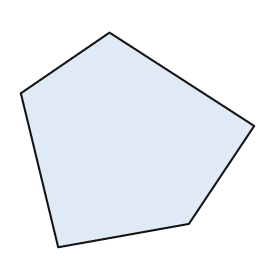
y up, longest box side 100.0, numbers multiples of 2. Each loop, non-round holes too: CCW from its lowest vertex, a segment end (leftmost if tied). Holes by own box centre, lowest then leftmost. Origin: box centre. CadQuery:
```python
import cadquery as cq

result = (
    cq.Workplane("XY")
    .moveTo(-34.0, -46.0)
    .lineTo(22.0, -36.0)
    .lineTo(50.0, 6.0)
    .lineTo(-12.0, 46.0)
    .lineTo(-50.0, 20.0)
    .close()
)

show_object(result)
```